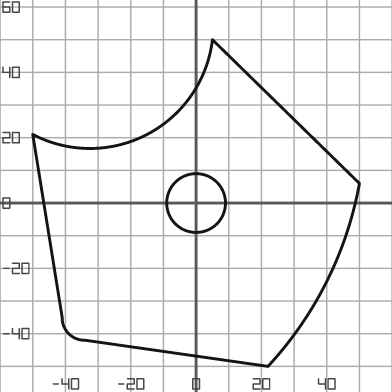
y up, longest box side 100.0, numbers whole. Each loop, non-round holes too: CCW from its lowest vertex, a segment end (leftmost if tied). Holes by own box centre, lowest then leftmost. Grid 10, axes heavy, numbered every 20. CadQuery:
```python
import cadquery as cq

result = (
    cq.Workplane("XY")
    .moveTo(22.0, -50.0)
    .threePointArc((40.0, -24.0), (50.0, 6.0))
    .lineTo(5.0, 50.0)
    .threePointArc((-15.0, 21.0), (-50.0, 21.0))
    .lineTo(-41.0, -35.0)
    .threePointArc((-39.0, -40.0), (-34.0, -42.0))
    .close()
    .moveTo(0.0, 0.0)
    .circle(9.0)
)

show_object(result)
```